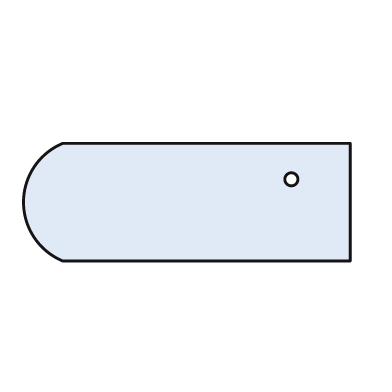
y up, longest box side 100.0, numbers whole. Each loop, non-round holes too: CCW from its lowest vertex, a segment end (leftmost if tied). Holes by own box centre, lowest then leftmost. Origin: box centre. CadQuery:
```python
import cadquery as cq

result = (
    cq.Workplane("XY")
    .moveTo(-38.0, -18.0)
    .lineTo(50.0, -18.0)
    .lineTo(50.0, 18.0)
    .lineTo(-38.0, 18.0)
    .threePointArc((-50.0, 0.0), (-38.0, -18.0))
    .close()
    .moveTo(32.0, 7.0)
    .circle(2.0)
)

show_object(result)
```